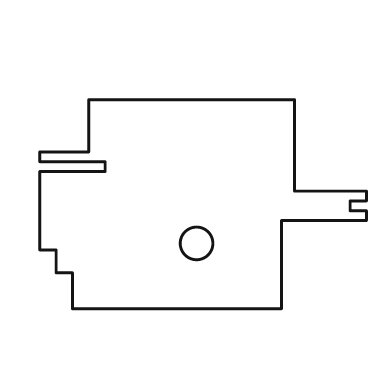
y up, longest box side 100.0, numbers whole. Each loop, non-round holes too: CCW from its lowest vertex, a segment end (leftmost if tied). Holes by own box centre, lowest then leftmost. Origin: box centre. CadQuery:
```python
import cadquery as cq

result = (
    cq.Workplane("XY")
    .moveTo(-40.0, -32.0)
    .lineTo(24.0, -32.0)
    .lineTo(24.0, -5.0)
    .lineTo(50.0, -5.0)
    .lineTo(50.0, -2.0)
    .lineTo(45.0, -2.0)
    .lineTo(45.0, 1.0)
    .lineTo(50.0, 1.0)
    .lineTo(50.0, 4.0)
    .lineTo(28.0, 4.0)
    .lineTo(28.0, 32.0)
    .lineTo(-35.0, 32.0)
    .lineTo(-35.0, 16.0)
    .lineTo(-50.0, 16.0)
    .lineTo(-50.0, 13.0)
    .lineTo(-30.0, 13.0)
    .lineTo(-30.0, 10.0)
    .lineTo(-50.0, 10.0)
    .lineTo(-50.0, -14.0)
    .lineTo(-45.0, -14.0)
    .lineTo(-45.0, -21.0)
    .lineTo(-40.0, -21.0)
    .close()
    .moveTo(-2.0, -12.0)
    .circle(5.0)
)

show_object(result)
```